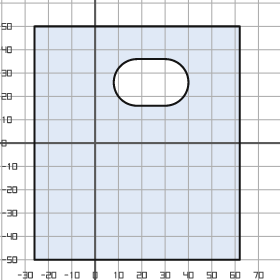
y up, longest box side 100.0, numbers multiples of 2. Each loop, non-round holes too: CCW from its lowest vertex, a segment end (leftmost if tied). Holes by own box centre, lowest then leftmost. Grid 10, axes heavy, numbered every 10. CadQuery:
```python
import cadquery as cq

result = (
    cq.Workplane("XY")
    .moveTo(-26.0, -50.0)
    .lineTo(62.0, -50.0)
    .lineTo(62.0, 50.0)
    .lineTo(-26.0, 50.0)
    .close()
    .moveTo(18.0, 16.0)
    .lineTo(30.0, 16.0)
    .threePointArc((40.0, 26.0), (30.0, 36.0))
    .lineTo(18.0, 36.0)
    .threePointArc((8.0, 26.0), (18.0, 16.0))
    .close()
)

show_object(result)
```